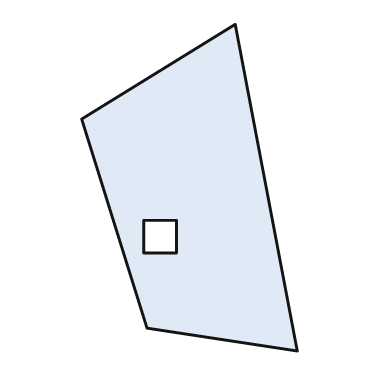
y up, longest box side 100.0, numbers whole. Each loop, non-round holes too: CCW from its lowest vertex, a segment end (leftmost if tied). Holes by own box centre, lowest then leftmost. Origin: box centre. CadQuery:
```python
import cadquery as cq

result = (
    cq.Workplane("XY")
    .moveTo(33.0, -50.0)
    .lineTo(14.0, 50.0)
    .lineTo(-33.0, 21.0)
    .lineTo(-13.0, -43.0)
    .close()
    .moveTo(-14.0, -20.0)
    .lineTo(-4.0, -20.0)
    .lineTo(-4.0, -10.0)
    .lineTo(-14.0, -10.0)
    .close()
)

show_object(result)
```